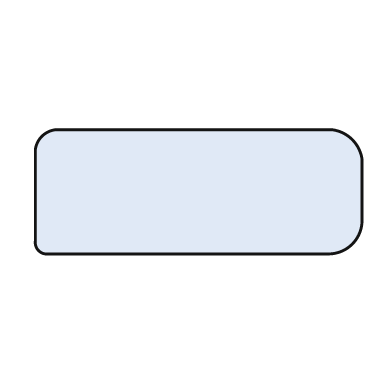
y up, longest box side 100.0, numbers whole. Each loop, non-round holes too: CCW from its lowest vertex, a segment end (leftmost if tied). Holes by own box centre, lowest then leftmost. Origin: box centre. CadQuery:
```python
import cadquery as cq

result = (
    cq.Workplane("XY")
    .moveTo(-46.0, -19.0)
    .lineTo(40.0, -19.0)
    .threePointArc((47.0, -16.0), (50.0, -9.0))
    .lineTo(50.0, 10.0)
    .threePointArc((47.0, 16.0), (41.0, 19.0))
    .lineTo(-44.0, 19.0)
    .threePointArc((-48.0, 17.0), (-50.0, 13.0))
    .lineTo(-50.0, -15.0)
    .threePointArc((-49.0, -18.0), (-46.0, -19.0))
    .close()
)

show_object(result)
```